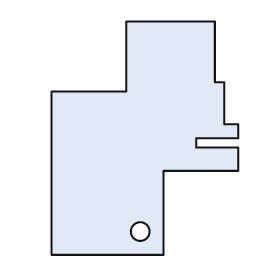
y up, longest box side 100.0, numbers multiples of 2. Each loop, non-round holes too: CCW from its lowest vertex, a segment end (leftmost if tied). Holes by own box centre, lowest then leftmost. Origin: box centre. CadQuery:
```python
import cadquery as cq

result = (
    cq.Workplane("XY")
    .moveTo(-40.0, -50.0)
    .lineTo(8.0, -50.0)
    .lineTo(8.0, -14.0)
    .lineTo(40.0, -14.0)
    .lineTo(40.0, -4.0)
    .lineTo(22.0, -4.0)
    .lineTo(22.0, 0.0)
    .lineTo(40.0, 0.0)
    .lineTo(40.0, 6.0)
    .lineTo(34.0, 6.0)
    .lineTo(34.0, 24.0)
    .lineTo(30.0, 24.0)
    .lineTo(30.0, 50.0)
    .lineTo(-8.0, 50.0)
    .lineTo(-8.0, 20.0)
    .lineTo(-40.0, 20.0)
    .close()
    .moveTo(-2.0, -40.0)
    .circle(4.0)
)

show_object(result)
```